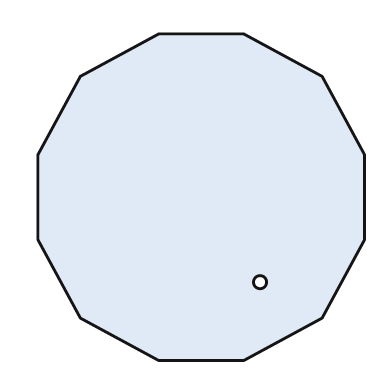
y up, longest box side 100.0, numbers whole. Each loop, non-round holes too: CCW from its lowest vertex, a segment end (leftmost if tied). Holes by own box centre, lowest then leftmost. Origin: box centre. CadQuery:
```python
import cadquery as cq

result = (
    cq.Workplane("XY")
    .moveTo(-13.0, -50.0)
    .lineTo(13.0, -50.0)
    .lineTo(37.0, -37.0)
    .lineTo(50.0, -13.0)
    .lineTo(50.0, 13.0)
    .lineTo(37.0, 37.0)
    .lineTo(13.0, 50.0)
    .lineTo(-13.0, 50.0)
    .lineTo(-37.0, 37.0)
    .lineTo(-50.0, 13.0)
    .lineTo(-50.0, -13.0)
    .lineTo(-37.0, -37.0)
    .close()
    .moveTo(18.0, -26.0)
    .circle(2.0)
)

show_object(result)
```